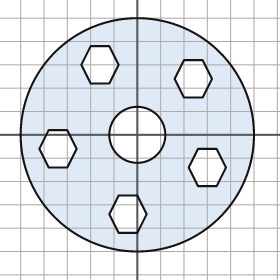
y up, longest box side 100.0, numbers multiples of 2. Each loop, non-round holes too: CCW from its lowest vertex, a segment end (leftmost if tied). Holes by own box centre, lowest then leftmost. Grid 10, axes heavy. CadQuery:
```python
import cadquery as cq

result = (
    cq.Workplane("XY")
    .moveTo(0.0, 0.0)
    .circle(50.0)
    .moveTo(-8.0, -42.0)
    .lineTo(0.0, -42.0)
    .lineTo(4.0, -34.0)
    .lineTo(0.0, -26.0)
    .lineTo(-8.0, -26.0)
    .lineTo(-12.0, -34.0)
    .close()
    .moveTo(26.0, -22.0)
    .lineTo(34.0, -22.0)
    .lineTo(38.0, -14.0)
    .lineTo(34.0, -6.0)
    .lineTo(26.0, -6.0)
    .lineTo(22.0, -14.0)
    .close()
    .moveTo(-38.0, -14.0)
    .lineTo(-30.0, -14.0)
    .lineTo(-26.0, -6.0)
    .lineTo(-30.0, 2.0)
    .lineTo(-38.0, 2.0)
    .lineTo(-42.0, -6.0)
    .close()
    .moveTo(0.0, 0.0)
    .circle(12.0)
    .moveTo(20.0, 16.0)
    .lineTo(28.0, 16.0)
    .lineTo(32.0, 24.0)
    .lineTo(28.0, 32.0)
    .lineTo(20.0, 32.0)
    .lineTo(16.0, 24.0)
    .close()
    .moveTo(-20.0, 22.0)
    .lineTo(-12.0, 22.0)
    .lineTo(-8.0, 30.0)
    .lineTo(-12.0, 38.0)
    .lineTo(-20.0, 38.0)
    .lineTo(-24.0, 30.0)
    .close()
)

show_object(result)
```